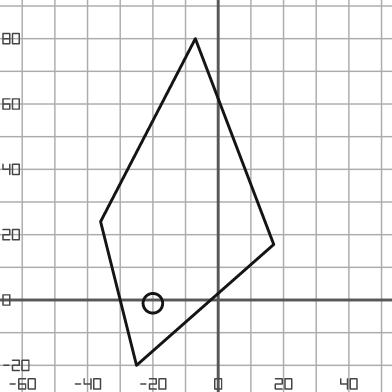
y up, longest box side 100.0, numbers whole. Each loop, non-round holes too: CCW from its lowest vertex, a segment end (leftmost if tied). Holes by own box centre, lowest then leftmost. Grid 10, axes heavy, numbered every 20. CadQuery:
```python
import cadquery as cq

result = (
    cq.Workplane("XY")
    .moveTo(-25.0, -20.0)
    .lineTo(17.0, 17.0)
    .lineTo(-7.0, 80.0)
    .lineTo(-36.0, 24.0)
    .close()
    .moveTo(-20.0, -1.0)
    .circle(3.0)
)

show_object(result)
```